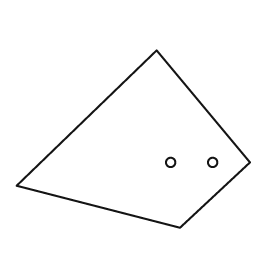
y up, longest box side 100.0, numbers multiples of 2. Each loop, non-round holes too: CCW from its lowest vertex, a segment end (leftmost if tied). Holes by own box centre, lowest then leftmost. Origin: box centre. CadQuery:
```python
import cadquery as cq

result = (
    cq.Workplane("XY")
    .moveTo(20.0, -38.0)
    .lineTo(50.0, -10.0)
    .lineTo(10.0, 38.0)
    .lineTo(-50.0, -20.0)
    .close()
    .moveTo(16.0, -10.0)
    .circle(2.0)
    .moveTo(34.0, -10.0)
    .circle(2.0)
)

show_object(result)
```